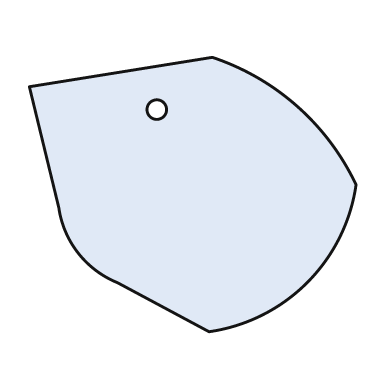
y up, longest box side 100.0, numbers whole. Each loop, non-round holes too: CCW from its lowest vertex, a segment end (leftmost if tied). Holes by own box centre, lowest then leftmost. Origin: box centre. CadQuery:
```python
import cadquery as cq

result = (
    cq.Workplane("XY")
    .moveTo(5.0, -42.0)
    .threePointArc((35.0, -27.0), (50.0, 3.0))
    .threePointArc((32.0, 27.0), (6.0, 42.0))
    .lineTo(-50.0, 33.0)
    .lineTo(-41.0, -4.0)
    .threePointArc((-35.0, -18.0), (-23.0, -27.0))
    .close()
    .moveTo(-11.0, 26.0)
    .circle(3.0)
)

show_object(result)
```